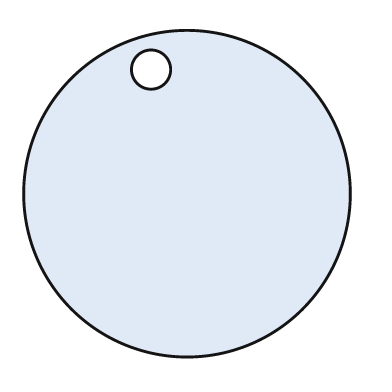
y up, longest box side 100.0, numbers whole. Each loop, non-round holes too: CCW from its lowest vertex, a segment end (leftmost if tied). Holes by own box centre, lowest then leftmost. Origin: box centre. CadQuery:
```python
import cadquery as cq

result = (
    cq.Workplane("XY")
    .moveTo(0.0, 0.0)
    .circle(50.0)
    .moveTo(-11.0, 38.0)
    .circle(6.0)
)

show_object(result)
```